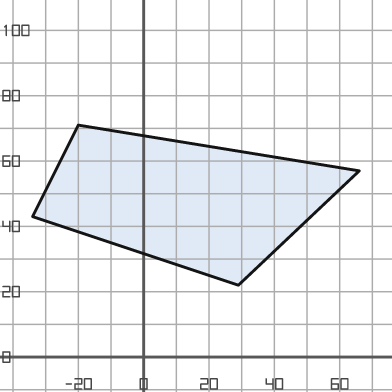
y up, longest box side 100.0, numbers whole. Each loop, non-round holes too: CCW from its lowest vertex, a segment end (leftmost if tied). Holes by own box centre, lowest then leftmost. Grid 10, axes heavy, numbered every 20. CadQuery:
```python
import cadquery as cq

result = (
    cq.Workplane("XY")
    .moveTo(29.0, 22.0)
    .lineTo(66.0, 57.0)
    .lineTo(-20.0, 71.0)
    .lineTo(-34.0, 43.0)
    .close()
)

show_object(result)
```